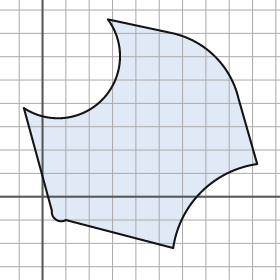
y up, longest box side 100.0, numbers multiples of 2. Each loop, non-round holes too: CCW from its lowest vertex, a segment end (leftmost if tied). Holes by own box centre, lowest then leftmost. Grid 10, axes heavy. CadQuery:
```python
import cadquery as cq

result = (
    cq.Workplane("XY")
    .moveTo(56.0, -22.0)
    .threePointArc((68.0, 2.0), (92.0, 14.0))
    .lineTo(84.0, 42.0)
    .threePointArc((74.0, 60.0), (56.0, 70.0))
    .lineTo(28.0, 76.0)
    .threePointArc((26.0, 42.0), (-8.0, 38.0))
    .lineTo(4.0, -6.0)
    .threePointArc((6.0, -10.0), (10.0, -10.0))
    .close()
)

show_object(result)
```